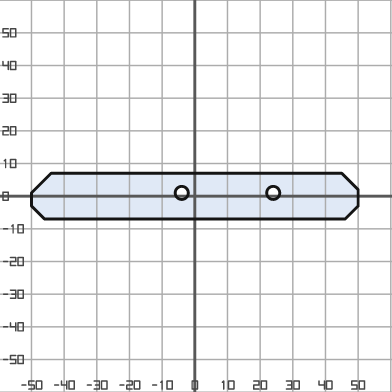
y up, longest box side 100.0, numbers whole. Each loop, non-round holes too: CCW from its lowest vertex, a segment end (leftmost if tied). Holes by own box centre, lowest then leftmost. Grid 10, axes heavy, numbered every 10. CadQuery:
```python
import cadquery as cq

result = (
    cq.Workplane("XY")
    .moveTo(-46.0, -7.0)
    .lineTo(46.0, -7.0)
    .lineTo(50.0, -3.0)
    .lineTo(50.0, 2.0)
    .lineTo(45.0, 7.0)
    .lineTo(-44.0, 7.0)
    .lineTo(-50.0, 1.0)
    .lineTo(-50.0, -3.0)
    .close()
    .moveTo(-4.0, 1.0)
    .circle(2.0)
    .moveTo(24.0, 1.0)
    .circle(2.0)
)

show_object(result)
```